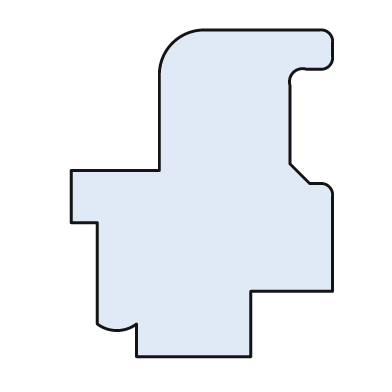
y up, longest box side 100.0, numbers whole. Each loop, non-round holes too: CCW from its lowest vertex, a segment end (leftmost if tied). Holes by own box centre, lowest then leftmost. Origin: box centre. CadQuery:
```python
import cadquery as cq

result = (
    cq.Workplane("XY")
    .moveTo(-20.0, -50.0)
    .lineTo(15.0, -50.0)
    .lineTo(15.0, -30.0)
    .lineTo(40.0, -30.0)
    .lineTo(40.0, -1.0)
    .threePointArc((39.0, 2.0), (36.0, 3.0))
    .lineTo(33.0, 3.0)
    .lineTo(27.0, 9.0)
    .lineTo(27.0, 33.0)
    .threePointArc((28.0, 37.0), (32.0, 38.0))
    .lineTo(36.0, 38.0)
    .threePointArc((39.0, 39.0), (40.0, 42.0))
    .lineTo(40.0, 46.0)
    .threePointArc((39.0, 49.0), (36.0, 50.0))
    .lineTo(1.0, 50.0)
    .threePointArc((-9.0, 46.0), (-13.0, 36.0))
    .lineTo(-13.0, 7.0)
    .lineTo(-40.0, 7.0)
    .lineTo(-40.0, -9.0)
    .lineTo(-32.0, -9.0)
    .lineTo(-32.0, -40.0)
    .threePointArc((-26.0, -42.0), (-20.0, -40.0))
    .close()
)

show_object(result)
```